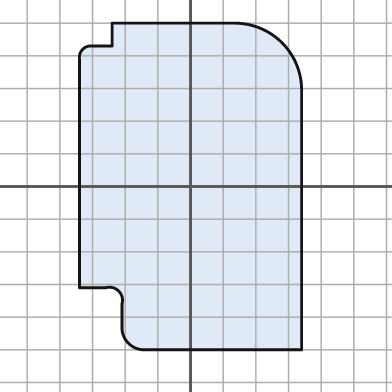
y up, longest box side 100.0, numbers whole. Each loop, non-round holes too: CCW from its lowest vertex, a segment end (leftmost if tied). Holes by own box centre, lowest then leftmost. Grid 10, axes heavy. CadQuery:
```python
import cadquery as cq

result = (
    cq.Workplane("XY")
    .moveTo(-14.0, -50.0)
    .lineTo(34.0, -50.0)
    .lineTo(34.0, 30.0)
    .threePointArc((28.0, 44.0), (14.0, 50.0))
    .lineTo(-24.0, 50.0)
    .lineTo(-24.0, 43.0)
    .lineTo(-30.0, 43.0)
    .threePointArc((-33.0, 42.0), (-34.0, 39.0))
    .lineTo(-34.0, -31.0)
    .lineTo(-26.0, -31.0)
    .threePointArc((-22.0, -32.0), (-21.0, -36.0))
    .lineTo(-21.0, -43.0)
    .threePointArc((-19.0, -48.0), (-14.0, -50.0))
    .close()
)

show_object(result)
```